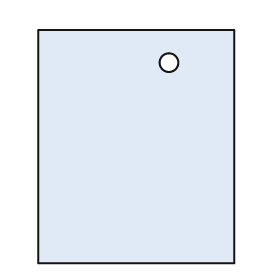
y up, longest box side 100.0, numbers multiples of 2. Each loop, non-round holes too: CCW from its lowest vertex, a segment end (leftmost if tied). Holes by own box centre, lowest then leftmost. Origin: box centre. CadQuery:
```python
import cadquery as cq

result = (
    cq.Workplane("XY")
    .moveTo(-42.0, -50.0)
    .lineTo(42.0, -50.0)
    .lineTo(42.0, 50.0)
    .lineTo(-42.0, 50.0)
    .close()
    .moveTo(14.0, 36.0)
    .circle(4.0)
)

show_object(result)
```